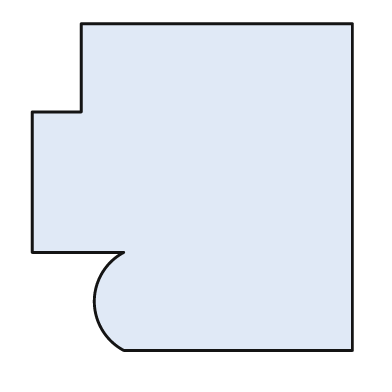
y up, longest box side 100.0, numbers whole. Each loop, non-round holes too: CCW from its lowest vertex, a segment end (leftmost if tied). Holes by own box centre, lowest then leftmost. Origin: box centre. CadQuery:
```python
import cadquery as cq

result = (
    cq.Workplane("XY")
    .moveTo(-21.0, -50.0)
    .lineTo(49.0, -50.0)
    .lineTo(49.0, 50.0)
    .lineTo(-34.0, 50.0)
    .lineTo(-34.0, 23.0)
    .lineTo(-49.0, 23.0)
    .lineTo(-49.0, -20.0)
    .lineTo(-21.0, -20.0)
    .threePointArc((-30.0, -35.0), (-21.0, -50.0))
    .close()
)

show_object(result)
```